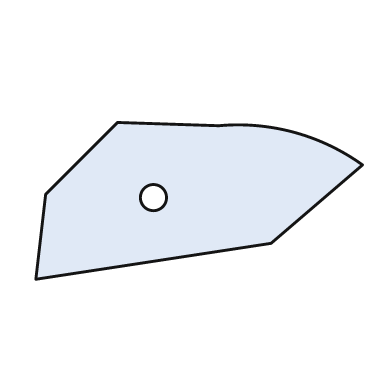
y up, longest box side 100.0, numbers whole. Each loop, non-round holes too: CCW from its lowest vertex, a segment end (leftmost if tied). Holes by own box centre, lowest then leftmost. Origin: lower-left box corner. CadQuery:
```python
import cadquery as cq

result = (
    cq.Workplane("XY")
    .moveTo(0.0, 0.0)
    .lineTo(72.0, 11.0)
    .lineTo(100.0, 35.0)
    .threePointArc((79.0, 45.0), (56.0, 47.0))
    .lineTo(25.0, 48.0)
    .lineTo(3.0, 26.0)
    .close()
    .moveTo(36.0, 25.0)
    .circle(4.0)
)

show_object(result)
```